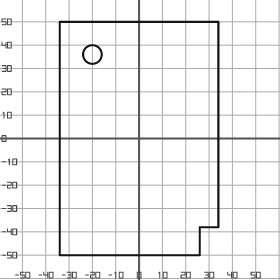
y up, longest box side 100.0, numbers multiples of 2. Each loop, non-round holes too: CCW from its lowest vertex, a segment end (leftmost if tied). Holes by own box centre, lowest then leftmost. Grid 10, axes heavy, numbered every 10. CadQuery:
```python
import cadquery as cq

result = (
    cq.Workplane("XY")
    .moveTo(-34.0, -50.0)
    .lineTo(26.0, -50.0)
    .lineTo(26.0, -38.0)
    .lineTo(34.0, -38.0)
    .lineTo(34.0, 50.0)
    .lineTo(-34.0, 50.0)
    .close()
    .moveTo(-20.0, 36.0)
    .circle(4.0)
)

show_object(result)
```